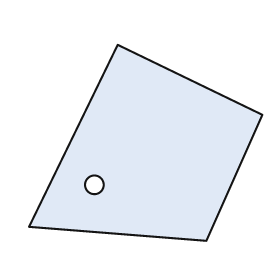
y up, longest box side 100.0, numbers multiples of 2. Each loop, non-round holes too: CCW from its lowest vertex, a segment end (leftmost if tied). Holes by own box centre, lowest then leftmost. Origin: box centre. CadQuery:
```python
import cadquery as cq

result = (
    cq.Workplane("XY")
    .moveTo(26.0, -42.0)
    .lineTo(50.0, 12.0)
    .lineTo(-12.0, 42.0)
    .lineTo(-50.0, -36.0)
    .close()
    .moveTo(-22.0, -18.0)
    .circle(4.0)
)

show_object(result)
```